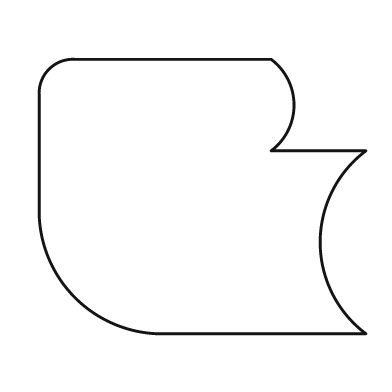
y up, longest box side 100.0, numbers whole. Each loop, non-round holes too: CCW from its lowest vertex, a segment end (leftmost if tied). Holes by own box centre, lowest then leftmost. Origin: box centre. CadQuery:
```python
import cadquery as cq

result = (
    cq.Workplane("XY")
    .moveTo(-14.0, -42.0)
    .lineTo(50.0, -42.0)
    .threePointArc((36.0, -14.0), (50.0, 14.0))
    .lineTo(21.0, 14.0)
    .threePointArc((28.0, 28.0), (21.0, 42.0))
    .lineTo(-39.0, 42.0)
    .threePointArc((-47.0, 39.0), (-50.0, 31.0))
    .lineTo(-50.0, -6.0)
    .threePointArc((-39.0, -31.0), (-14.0, -42.0))
    .close()
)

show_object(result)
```